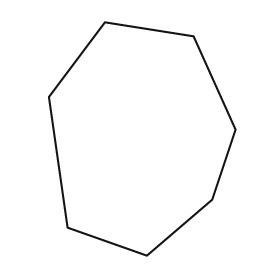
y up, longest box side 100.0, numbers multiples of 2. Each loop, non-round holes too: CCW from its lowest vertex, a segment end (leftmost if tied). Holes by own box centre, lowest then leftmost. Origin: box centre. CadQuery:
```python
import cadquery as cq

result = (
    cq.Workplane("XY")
    .moveTo(2.0, -50.0)
    .lineTo(30.0, -26.0)
    .lineTo(40.0, 4.0)
    .lineTo(22.0, 44.0)
    .lineTo(-16.0, 50.0)
    .lineTo(-40.0, 18.0)
    .lineTo(-32.0, -38.0)
    .close()
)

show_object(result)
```